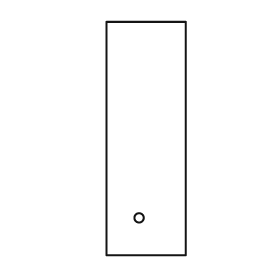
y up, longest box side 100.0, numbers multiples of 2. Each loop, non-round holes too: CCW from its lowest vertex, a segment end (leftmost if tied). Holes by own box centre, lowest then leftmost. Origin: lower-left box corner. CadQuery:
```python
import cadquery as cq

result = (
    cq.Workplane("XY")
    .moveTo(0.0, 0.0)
    .lineTo(34.0, 0.0)
    .lineTo(34.0, 100.0)
    .lineTo(0.0, 100.0)
    .close()
    .moveTo(14.0, 16.0)
    .circle(2.0)
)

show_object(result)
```